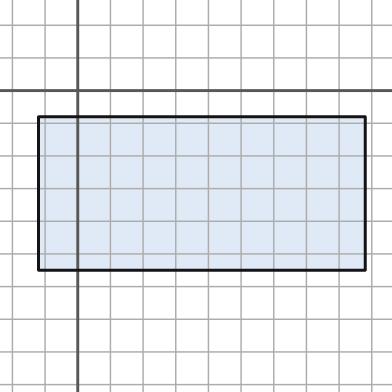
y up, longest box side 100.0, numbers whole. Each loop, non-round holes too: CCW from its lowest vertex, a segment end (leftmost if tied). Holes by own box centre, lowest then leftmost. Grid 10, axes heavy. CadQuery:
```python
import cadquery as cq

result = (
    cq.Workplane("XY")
    .moveTo(-12.0, -55.0)
    .lineTo(88.0, -55.0)
    .lineTo(88.0, -8.0)
    .lineTo(-12.0, -8.0)
    .close()
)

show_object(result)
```